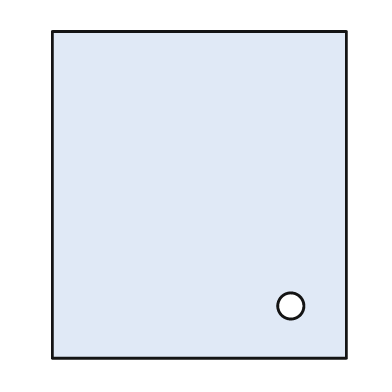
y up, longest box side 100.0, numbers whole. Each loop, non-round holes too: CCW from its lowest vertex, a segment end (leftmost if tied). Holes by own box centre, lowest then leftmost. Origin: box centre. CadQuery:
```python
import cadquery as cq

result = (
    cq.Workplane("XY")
    .moveTo(-45.0, -50.0)
    .lineTo(45.0, -50.0)
    .lineTo(45.0, 50.0)
    .lineTo(-45.0, 50.0)
    .close()
    .moveTo(28.0, -34.0)
    .circle(4.0)
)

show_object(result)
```